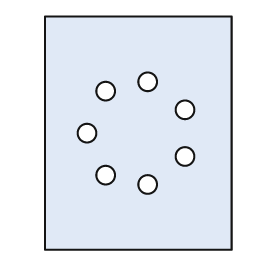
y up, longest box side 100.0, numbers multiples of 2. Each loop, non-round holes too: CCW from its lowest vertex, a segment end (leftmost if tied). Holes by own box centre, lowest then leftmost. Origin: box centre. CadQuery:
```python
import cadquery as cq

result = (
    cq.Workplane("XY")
    .moveTo(-40.0, -50.0)
    .lineTo(40.0, -50.0)
    .lineTo(40.0, 50.0)
    .lineTo(-40.0, 50.0)
    .close()
    .moveTo(4.0, -22.0)
    .circle(4.0)
    .moveTo(-14.0, -18.0)
    .circle(4.0)
    .moveTo(20.0, -10.0)
    .circle(4.0)
    .moveTo(-22.0, 0.0)
    .circle(4.0)
    .moveTo(20.0, 10.0)
    .circle(4.0)
    .moveTo(-14.0, 18.0)
    .circle(4.0)
    .moveTo(4.0, 22.0)
    .circle(4.0)
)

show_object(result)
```